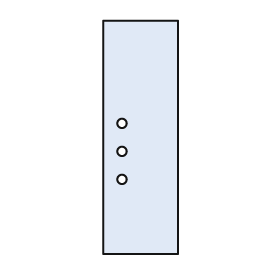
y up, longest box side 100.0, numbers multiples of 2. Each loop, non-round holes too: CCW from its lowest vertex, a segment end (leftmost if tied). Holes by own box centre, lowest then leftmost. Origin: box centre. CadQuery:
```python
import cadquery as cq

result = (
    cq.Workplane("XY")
    .moveTo(-16.0, -50.0)
    .lineTo(16.0, -50.0)
    .lineTo(16.0, 50.0)
    .lineTo(-16.0, 50.0)
    .close()
    .moveTo(-8.0, -18.0)
    .circle(2.0)
    .moveTo(-8.0, -6.0)
    .circle(2.0)
    .moveTo(-8.0, 6.0)
    .circle(2.0)
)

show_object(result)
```